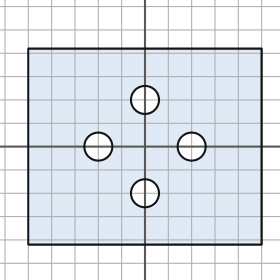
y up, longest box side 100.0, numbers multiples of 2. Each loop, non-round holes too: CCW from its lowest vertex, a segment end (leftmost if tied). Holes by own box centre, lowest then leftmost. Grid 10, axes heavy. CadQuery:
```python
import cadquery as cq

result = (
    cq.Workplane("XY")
    .moveTo(-50.0, -42.0)
    .lineTo(50.0, -42.0)
    .lineTo(50.0, 42.0)
    .lineTo(-50.0, 42.0)
    .close()
    .moveTo(0.0, -20.0)
    .circle(6.0)
    .moveTo(-20.0, 0.0)
    .circle(6.0)
    .moveTo(20.0, 0.0)
    .circle(6.0)
    .moveTo(0.0, 20.0)
    .circle(6.0)
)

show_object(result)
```